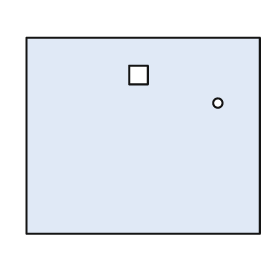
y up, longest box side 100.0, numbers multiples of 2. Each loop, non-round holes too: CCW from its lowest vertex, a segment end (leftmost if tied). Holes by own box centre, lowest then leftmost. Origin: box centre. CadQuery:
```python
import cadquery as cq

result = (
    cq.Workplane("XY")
    .moveTo(-50.0, -42.0)
    .lineTo(50.0, -42.0)
    .lineTo(50.0, 42.0)
    .lineTo(-50.0, 42.0)
    .close()
    .moveTo(32.0, 14.0)
    .circle(2.0)
    .moveTo(-6.0, 22.0)
    .lineTo(2.0, 22.0)
    .lineTo(2.0, 30.0)
    .lineTo(-6.0, 30.0)
    .close()
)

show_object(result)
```